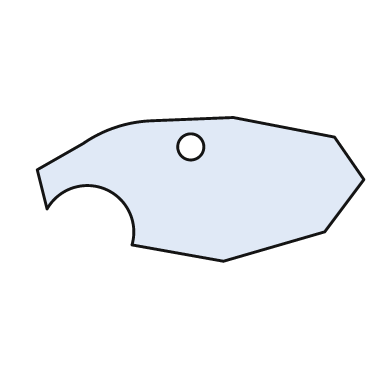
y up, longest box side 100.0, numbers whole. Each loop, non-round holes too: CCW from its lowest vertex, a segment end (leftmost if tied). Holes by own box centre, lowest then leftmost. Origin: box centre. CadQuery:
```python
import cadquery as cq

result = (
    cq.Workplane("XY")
    .moveTo(7.0, -22.0)
    .lineTo(38.0, -13.0)
    .lineTo(50.0, 3.0)
    .lineTo(41.0, 16.0)
    .lineTo(10.0, 22.0)
    .lineTo(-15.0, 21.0)
    .threePointArc((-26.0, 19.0), (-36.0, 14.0))
    .lineTo(-50.0, 6.0)
    .lineTo(-47.0, -6.0)
    .threePointArc((-29.0, 0.0), (-21.0, -17.0))
    .close()
    .moveTo(-3.0, 13.0)
    .circle(4.0)
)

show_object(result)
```